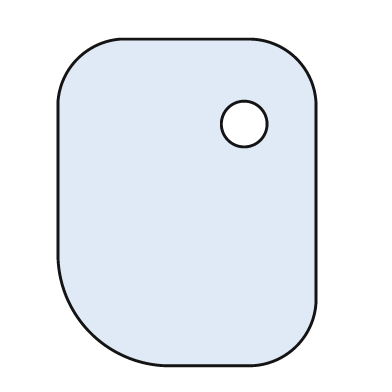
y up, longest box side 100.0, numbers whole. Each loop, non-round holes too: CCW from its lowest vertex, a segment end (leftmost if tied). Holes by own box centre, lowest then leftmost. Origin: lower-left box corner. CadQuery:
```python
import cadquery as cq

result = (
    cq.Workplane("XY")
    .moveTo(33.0, 0.0)
    .lineTo(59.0, 0.0)
    .threePointArc((73.0, 6.0), (79.0, 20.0))
    .lineTo(79.0, 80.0)
    .threePointArc((73.0, 94.0), (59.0, 100.0))
    .lineTo(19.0, 100.0)
    .threePointArc((6.0, 94.0), (0.0, 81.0))
    .lineTo(0.0, 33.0)
    .threePointArc((10.0, 10.0), (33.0, 0.0))
    .close()
    .moveTo(57.0, 74.0)
    .circle(7.0)
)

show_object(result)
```